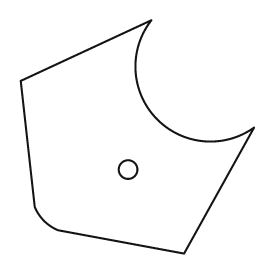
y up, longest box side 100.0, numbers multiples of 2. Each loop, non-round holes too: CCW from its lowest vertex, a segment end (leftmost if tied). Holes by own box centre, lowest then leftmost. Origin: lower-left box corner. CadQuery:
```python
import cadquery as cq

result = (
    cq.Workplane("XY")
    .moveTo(70.0, 0.0)
    .lineTo(100.0, 54.0)
    .threePointArc((58.0, 58.0), (56.0, 100.0))
    .lineTo(0.0, 74.0)
    .lineTo(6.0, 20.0)
    .threePointArc((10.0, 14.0), (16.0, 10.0))
    .close()
    .moveTo(46.0, 36.0)
    .circle(4.0)
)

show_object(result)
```